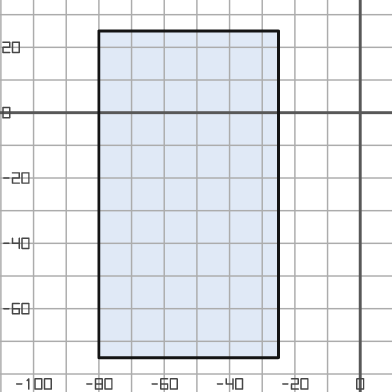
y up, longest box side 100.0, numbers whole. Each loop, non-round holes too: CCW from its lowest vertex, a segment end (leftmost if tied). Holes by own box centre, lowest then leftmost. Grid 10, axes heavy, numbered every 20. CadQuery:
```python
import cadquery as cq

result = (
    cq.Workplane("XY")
    .moveTo(-80.0, -75.0)
    .lineTo(-25.0, -75.0)
    .lineTo(-25.0, 25.0)
    .lineTo(-80.0, 25.0)
    .close()
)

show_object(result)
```